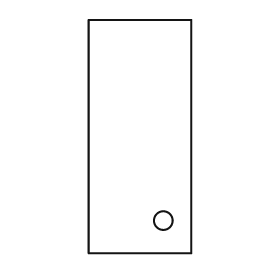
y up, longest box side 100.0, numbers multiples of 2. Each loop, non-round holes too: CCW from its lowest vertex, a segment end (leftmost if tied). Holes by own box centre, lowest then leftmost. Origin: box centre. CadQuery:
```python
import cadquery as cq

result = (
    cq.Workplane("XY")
    .moveTo(-22.0, -50.0)
    .lineTo(22.0, -50.0)
    .lineTo(22.0, 50.0)
    .lineTo(-22.0, 50.0)
    .close()
    .moveTo(10.0, -36.0)
    .circle(4.0)
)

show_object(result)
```